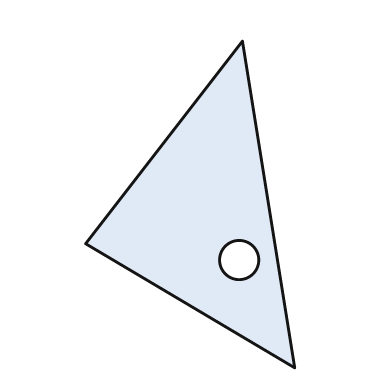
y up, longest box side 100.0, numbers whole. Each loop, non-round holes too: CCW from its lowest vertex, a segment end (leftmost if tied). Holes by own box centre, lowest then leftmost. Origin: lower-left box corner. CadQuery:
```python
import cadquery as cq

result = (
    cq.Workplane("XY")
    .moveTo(64.0, 0.0)
    .lineTo(48.0, 100.0)
    .lineTo(0.0, 38.0)
    .close()
    .moveTo(47.0, 33.0)
    .circle(6.0)
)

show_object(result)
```